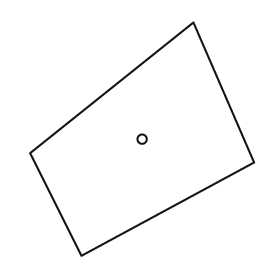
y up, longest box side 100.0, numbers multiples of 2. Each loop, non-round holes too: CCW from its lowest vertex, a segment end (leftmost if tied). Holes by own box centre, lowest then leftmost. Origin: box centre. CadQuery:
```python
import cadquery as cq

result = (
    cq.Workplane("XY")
    .moveTo(-26.0, -50.0)
    .lineTo(48.0, -10.0)
    .lineTo(22.0, 50.0)
    .lineTo(-48.0, -6.0)
    .close()
    .moveTo(0.0, 0.0)
    .circle(2.0)
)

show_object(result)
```